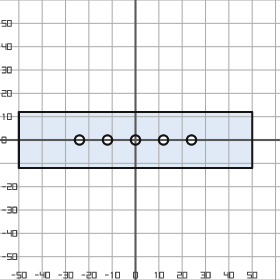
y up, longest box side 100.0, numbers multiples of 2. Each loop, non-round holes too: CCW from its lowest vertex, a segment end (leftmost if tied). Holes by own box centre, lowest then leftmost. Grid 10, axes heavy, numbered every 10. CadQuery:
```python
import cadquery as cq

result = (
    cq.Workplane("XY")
    .moveTo(-50.0, -12.0)
    .lineTo(50.0, -12.0)
    .lineTo(50.0, 12.0)
    .lineTo(-50.0, 12.0)
    .close()
    .moveTo(-24.0, 0.0)
    .circle(2.0)
    .moveTo(-12.0, 0.0)
    .circle(2.0)
    .moveTo(0.0, 0.0)
    .circle(2.0)
    .moveTo(12.0, 0.0)
    .circle(2.0)
    .moveTo(24.0, 0.0)
    .circle(2.0)
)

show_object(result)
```